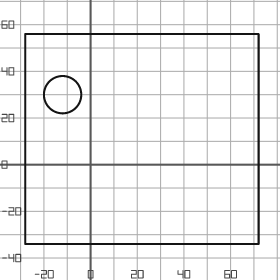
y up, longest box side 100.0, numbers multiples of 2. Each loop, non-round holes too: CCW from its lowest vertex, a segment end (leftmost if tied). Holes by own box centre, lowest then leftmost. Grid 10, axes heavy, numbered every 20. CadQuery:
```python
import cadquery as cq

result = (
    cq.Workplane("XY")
    .moveTo(-28.0, -34.0)
    .lineTo(72.0, -34.0)
    .lineTo(72.0, 56.0)
    .lineTo(-28.0, 56.0)
    .close()
    .moveTo(-12.0, 30.0)
    .circle(8.0)
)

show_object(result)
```